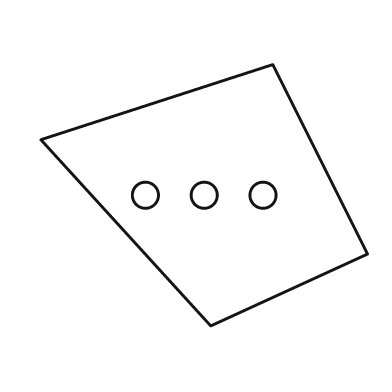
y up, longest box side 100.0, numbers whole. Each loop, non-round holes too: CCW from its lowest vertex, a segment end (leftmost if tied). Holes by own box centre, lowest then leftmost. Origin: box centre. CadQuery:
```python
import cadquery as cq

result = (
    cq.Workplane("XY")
    .moveTo(2.0, -40.0)
    .lineTo(50.0, -18.0)
    .lineTo(21.0, 40.0)
    .lineTo(-50.0, 17.0)
    .close()
    .moveTo(-18.0, 0.0)
    .circle(4.0)
    .moveTo(0.0, 0.0)
    .circle(4.0)
    .moveTo(18.0, 0.0)
    .circle(4.0)
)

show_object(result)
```